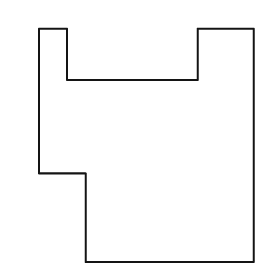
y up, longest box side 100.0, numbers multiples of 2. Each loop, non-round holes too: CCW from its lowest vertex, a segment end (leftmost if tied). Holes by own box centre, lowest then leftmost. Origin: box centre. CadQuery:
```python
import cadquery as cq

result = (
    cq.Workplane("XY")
    .moveTo(-26.0, -50.0)
    .lineTo(46.0, -50.0)
    .lineTo(46.0, 50.0)
    .lineTo(22.0, 50.0)
    .lineTo(22.0, 28.0)
    .lineTo(-34.0, 28.0)
    .lineTo(-34.0, 50.0)
    .lineTo(-46.0, 50.0)
    .lineTo(-46.0, -12.0)
    .lineTo(-26.0, -12.0)
    .close()
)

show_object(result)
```